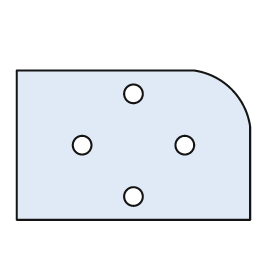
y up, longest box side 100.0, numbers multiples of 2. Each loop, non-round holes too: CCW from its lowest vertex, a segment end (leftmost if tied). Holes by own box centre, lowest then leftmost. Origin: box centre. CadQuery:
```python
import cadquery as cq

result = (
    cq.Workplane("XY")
    .moveTo(-50.0, -32.0)
    .lineTo(50.0, -32.0)
    .lineTo(50.0, 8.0)
    .threePointArc((42.0, 24.0), (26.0, 32.0))
    .lineTo(-50.0, 32.0)
    .close()
    .moveTo(0.0, -22.0)
    .circle(4.0)
    .moveTo(-22.0, 0.0)
    .circle(4.0)
    .moveTo(22.0, 0.0)
    .circle(4.0)
    .moveTo(0.0, 22.0)
    .circle(4.0)
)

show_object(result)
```